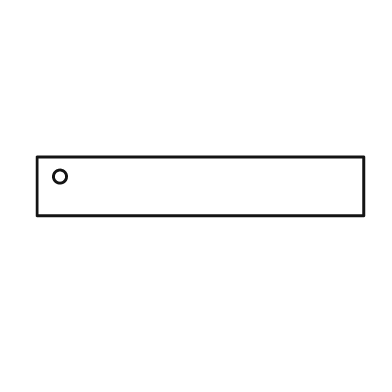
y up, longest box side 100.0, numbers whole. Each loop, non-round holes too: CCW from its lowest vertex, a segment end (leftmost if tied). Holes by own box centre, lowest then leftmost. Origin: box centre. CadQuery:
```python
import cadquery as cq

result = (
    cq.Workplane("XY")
    .moveTo(-50.0, -9.0)
    .lineTo(50.0, -9.0)
    .lineTo(50.0, 9.0)
    .lineTo(-50.0, 9.0)
    .close()
    .moveTo(-43.0, 3.0)
    .circle(2.0)
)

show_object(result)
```